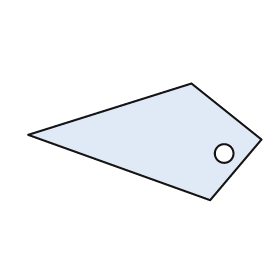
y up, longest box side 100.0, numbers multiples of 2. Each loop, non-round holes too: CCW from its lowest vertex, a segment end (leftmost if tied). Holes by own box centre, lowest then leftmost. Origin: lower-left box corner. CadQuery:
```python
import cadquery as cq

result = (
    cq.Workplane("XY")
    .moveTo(78.0, 0.0)
    .lineTo(100.0, 26.0)
    .lineTo(70.0, 50.0)
    .lineTo(0.0, 28.0)
    .close()
    .moveTo(84.0, 20.0)
    .circle(4.0)
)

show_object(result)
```